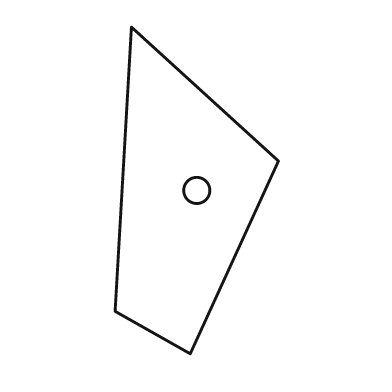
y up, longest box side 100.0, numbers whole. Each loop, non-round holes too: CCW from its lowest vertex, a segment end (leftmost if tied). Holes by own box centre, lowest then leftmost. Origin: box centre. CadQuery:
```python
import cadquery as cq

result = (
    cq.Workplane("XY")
    .moveTo(-2.0, -50.0)
    .lineTo(25.0, 9.0)
    .lineTo(-20.0, 50.0)
    .lineTo(-25.0, -37.0)
    .close()
    .moveTo(0.0, 0.0)
    .circle(4.0)
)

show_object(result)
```